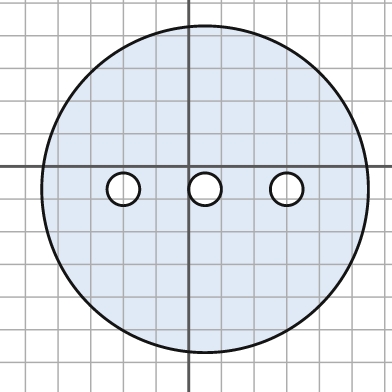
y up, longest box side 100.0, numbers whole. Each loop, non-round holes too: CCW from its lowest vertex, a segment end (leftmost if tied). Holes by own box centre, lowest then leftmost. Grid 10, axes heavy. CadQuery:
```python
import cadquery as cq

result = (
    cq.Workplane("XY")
    .moveTo(5.0, -7.0)
    .circle(50.0)
    .moveTo(-20.0, -7.0)
    .circle(5.0)
    .moveTo(5.0, -7.0)
    .circle(5.0)
    .moveTo(30.0, -7.0)
    .circle(5.0)
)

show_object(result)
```